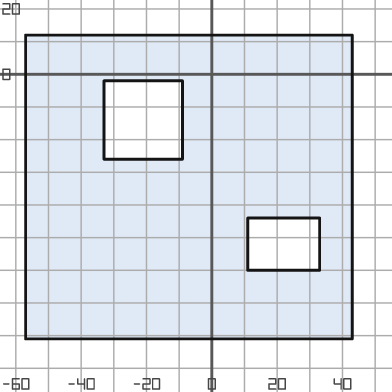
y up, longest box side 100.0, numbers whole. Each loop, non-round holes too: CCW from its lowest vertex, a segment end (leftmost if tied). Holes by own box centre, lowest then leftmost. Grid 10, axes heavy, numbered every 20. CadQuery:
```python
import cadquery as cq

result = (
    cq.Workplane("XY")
    .moveTo(-57.0, -81.0)
    .lineTo(43.0, -81.0)
    .lineTo(43.0, 12.0)
    .lineTo(-57.0, 12.0)
    .close()
    .moveTo(11.0, -60.0)
    .lineTo(33.0, -60.0)
    .lineTo(33.0, -44.0)
    .lineTo(11.0, -44.0)
    .close()
    .moveTo(-33.0, -26.0)
    .lineTo(-9.0, -26.0)
    .lineTo(-9.0, -2.0)
    .lineTo(-33.0, -2.0)
    .close()
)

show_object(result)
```